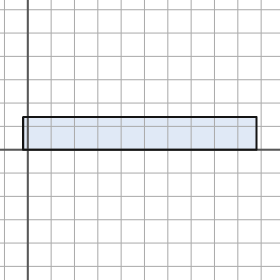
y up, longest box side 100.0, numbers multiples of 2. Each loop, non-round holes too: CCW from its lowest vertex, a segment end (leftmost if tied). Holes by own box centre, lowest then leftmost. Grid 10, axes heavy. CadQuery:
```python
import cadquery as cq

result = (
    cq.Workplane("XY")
    .moveTo(-2.0, 0.0)
    .lineTo(98.0, 0.0)
    .lineTo(98.0, 14.0)
    .lineTo(-2.0, 14.0)
    .close()
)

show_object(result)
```